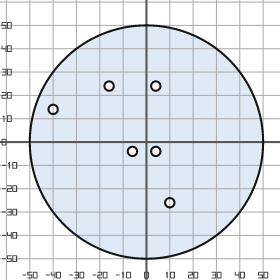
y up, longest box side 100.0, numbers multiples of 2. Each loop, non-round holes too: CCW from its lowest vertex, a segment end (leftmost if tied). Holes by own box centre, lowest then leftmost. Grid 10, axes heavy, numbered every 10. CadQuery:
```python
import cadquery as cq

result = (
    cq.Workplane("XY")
    .moveTo(0.0, 0.0)
    .circle(50.0)
    .moveTo(10.0, -26.0)
    .circle(2.0)
    .moveTo(-6.0, -4.0)
    .circle(2.0)
    .moveTo(4.0, -4.0)
    .circle(2.0)
    .moveTo(-40.0, 14.0)
    .circle(2.0)
    .moveTo(-16.0, 24.0)
    .circle(2.0)
    .moveTo(4.0, 24.0)
    .circle(2.0)
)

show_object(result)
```